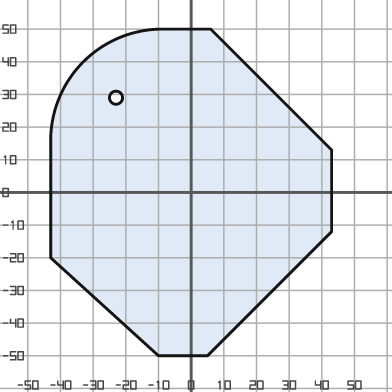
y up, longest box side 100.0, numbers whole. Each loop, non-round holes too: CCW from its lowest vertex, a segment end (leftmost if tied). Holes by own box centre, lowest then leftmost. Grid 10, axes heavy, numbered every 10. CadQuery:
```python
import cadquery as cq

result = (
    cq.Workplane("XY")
    .moveTo(-10.0, -50.0)
    .lineTo(5.0, -50.0)
    .lineTo(43.0, -12.0)
    .lineTo(43.0, 13.0)
    .lineTo(6.0, 50.0)
    .lineTo(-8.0, 50.0)
    .threePointArc((-33.0, 40.0), (-43.0, 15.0))
    .lineTo(-43.0, -20.0)
    .close()
    .moveTo(-23.0, 29.0)
    .circle(2.0)
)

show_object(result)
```